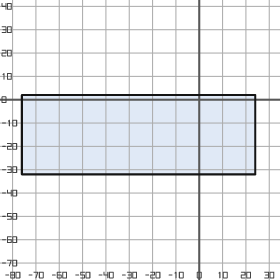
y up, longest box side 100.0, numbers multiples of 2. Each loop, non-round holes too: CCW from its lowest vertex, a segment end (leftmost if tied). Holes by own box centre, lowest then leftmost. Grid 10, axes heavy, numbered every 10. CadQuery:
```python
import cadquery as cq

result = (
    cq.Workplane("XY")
    .moveTo(-76.0, -32.0)
    .lineTo(24.0, -32.0)
    .lineTo(24.0, 2.0)
    .lineTo(-76.0, 2.0)
    .close()
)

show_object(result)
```